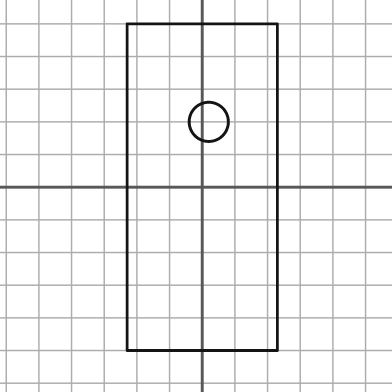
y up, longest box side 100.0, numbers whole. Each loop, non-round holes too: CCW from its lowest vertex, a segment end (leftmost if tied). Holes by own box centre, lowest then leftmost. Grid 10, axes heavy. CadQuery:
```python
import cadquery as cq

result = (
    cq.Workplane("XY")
    .moveTo(-23.0, -50.0)
    .lineTo(23.0, -50.0)
    .lineTo(23.0, 50.0)
    .lineTo(-23.0, 50.0)
    .close()
    .moveTo(2.0, 20.0)
    .circle(6.0)
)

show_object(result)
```